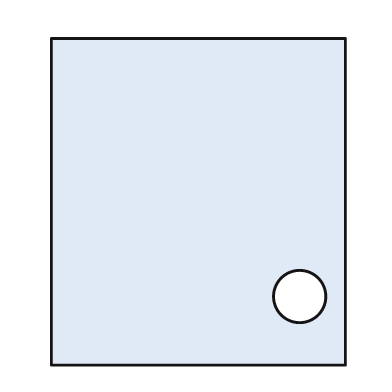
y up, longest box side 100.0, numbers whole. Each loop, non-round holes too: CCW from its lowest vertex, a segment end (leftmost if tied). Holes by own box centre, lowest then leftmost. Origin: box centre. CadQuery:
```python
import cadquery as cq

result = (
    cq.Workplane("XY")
    .moveTo(-45.0, -50.0)
    .lineTo(45.0, -50.0)
    .lineTo(45.0, 50.0)
    .lineTo(-45.0, 50.0)
    .close()
    .moveTo(31.0, -29.0)
    .circle(8.0)
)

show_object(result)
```